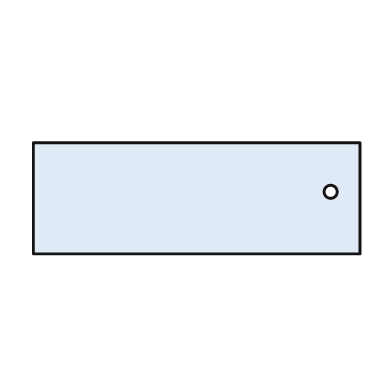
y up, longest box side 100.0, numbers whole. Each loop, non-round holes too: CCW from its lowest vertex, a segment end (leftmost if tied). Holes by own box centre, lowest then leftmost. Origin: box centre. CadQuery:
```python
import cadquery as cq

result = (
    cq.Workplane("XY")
    .moveTo(-50.0, -17.0)
    .lineTo(50.0, -17.0)
    .lineTo(50.0, 17.0)
    .lineTo(-50.0, 17.0)
    .close()
    .moveTo(41.0, 2.0)
    .circle(2.0)
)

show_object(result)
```